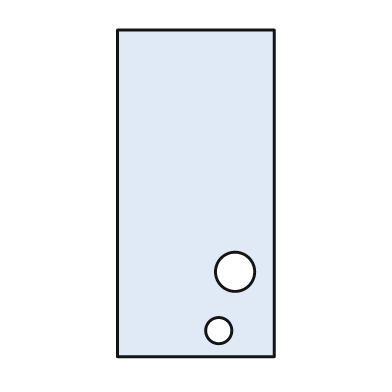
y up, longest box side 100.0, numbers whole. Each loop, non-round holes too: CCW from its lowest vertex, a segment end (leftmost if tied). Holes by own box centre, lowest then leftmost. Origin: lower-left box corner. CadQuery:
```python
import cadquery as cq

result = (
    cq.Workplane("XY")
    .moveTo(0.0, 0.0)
    .lineTo(48.0, 0.0)
    .lineTo(48.0, 100.0)
    .lineTo(0.0, 100.0)
    .close()
    .moveTo(31.0, 8.0)
    .circle(4.0)
    .moveTo(36.0, 26.0)
    .circle(6.0)
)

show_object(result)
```